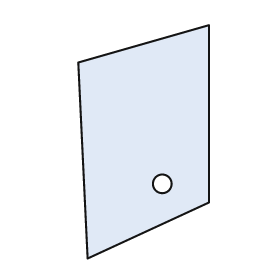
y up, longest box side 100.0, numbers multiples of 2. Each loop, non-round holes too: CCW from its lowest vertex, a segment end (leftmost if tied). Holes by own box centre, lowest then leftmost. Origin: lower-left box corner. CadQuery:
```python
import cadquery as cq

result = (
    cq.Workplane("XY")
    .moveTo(4.0, 0.0)
    .lineTo(56.0, 24.0)
    .lineTo(56.0, 100.0)
    .lineTo(0.0, 84.0)
    .close()
    .moveTo(36.0, 32.0)
    .circle(4.0)
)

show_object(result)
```